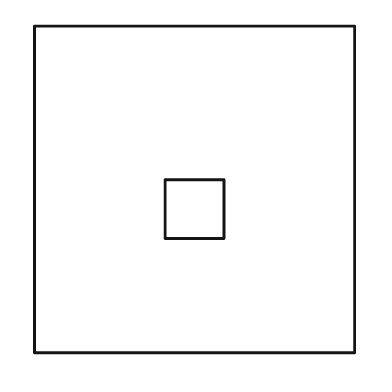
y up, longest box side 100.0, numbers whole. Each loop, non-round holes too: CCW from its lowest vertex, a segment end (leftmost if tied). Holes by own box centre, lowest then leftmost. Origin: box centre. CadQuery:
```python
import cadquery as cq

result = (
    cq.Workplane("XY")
    .moveTo(-49.0, -50.0)
    .lineTo(49.0, -50.0)
    .lineTo(49.0, 50.0)
    .lineTo(-49.0, 50.0)
    .close()
    .moveTo(-9.0, -15.0)
    .lineTo(9.0, -15.0)
    .lineTo(9.0, 3.0)
    .lineTo(-9.0, 3.0)
    .close()
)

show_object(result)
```